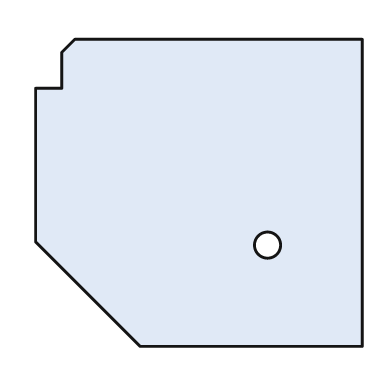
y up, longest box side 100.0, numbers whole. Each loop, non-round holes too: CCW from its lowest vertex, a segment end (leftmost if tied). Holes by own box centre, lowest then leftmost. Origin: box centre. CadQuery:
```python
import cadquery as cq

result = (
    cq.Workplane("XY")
    .moveTo(-18.0, -47.0)
    .lineTo(50.0, -47.0)
    .lineTo(50.0, 47.0)
    .lineTo(-38.0, 47.0)
    .lineTo(-42.0, 43.0)
    .lineTo(-42.0, 32.0)
    .lineTo(-50.0, 32.0)
    .lineTo(-50.0, -15.0)
    .close()
    .moveTo(21.0, -16.0)
    .circle(4.0)
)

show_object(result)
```